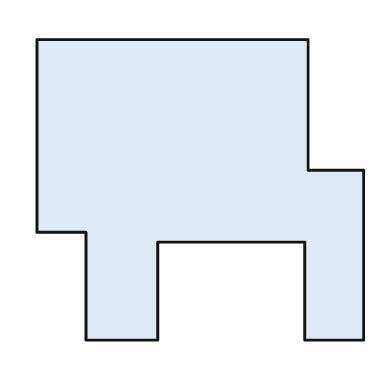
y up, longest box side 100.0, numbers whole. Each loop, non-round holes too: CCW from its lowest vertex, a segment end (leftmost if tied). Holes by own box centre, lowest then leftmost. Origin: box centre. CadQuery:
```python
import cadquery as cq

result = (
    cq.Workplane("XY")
    .moveTo(-35.0, -46.0)
    .lineTo(-13.0, -46.0)
    .lineTo(-13.0, -16.0)
    .lineTo(32.0, -16.0)
    .lineTo(32.0, -46.0)
    .lineTo(50.0, -46.0)
    .lineTo(50.0, 6.0)
    .lineTo(33.0, 6.0)
    .lineTo(33.0, 46.0)
    .lineTo(-50.0, 46.0)
    .lineTo(-50.0, -13.0)
    .lineTo(-35.0, -13.0)
    .close()
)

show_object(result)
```